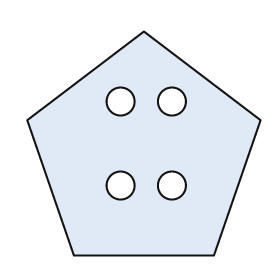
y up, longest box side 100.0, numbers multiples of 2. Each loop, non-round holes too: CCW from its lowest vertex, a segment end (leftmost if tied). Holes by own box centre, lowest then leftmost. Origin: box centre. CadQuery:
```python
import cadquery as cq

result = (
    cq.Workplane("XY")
    .moveTo(-30.0, -48.0)
    .lineTo(30.0, -48.0)
    .lineTo(50.0, 10.0)
    .lineTo(0.0, 48.0)
    .lineTo(-50.0, 10.0)
    .close()
    .moveTo(-10.0, -18.0)
    .circle(6.0)
    .moveTo(12.0, -18.0)
    .circle(6.0)
    .moveTo(-10.0, 18.0)
    .circle(6.0)
    .moveTo(12.0, 18.0)
    .circle(6.0)
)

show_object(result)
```